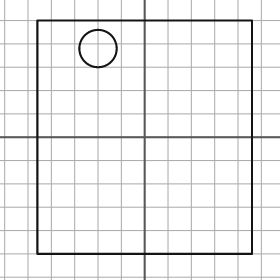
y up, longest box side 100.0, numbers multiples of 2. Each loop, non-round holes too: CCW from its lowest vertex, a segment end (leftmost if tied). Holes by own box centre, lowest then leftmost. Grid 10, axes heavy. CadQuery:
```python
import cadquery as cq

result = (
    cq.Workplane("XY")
    .moveTo(-46.0, -50.0)
    .lineTo(46.0, -50.0)
    .lineTo(46.0, 50.0)
    .lineTo(-46.0, 50.0)
    .close()
    .moveTo(-20.0, 38.0)
    .circle(8.0)
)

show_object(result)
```